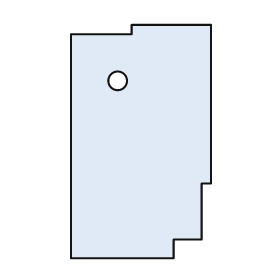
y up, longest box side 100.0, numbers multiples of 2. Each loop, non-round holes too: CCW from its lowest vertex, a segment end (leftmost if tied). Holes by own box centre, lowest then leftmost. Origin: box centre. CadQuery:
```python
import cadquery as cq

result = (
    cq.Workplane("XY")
    .moveTo(-30.0, -50.0)
    .lineTo(14.0, -50.0)
    .lineTo(14.0, -42.0)
    .lineTo(26.0, -42.0)
    .lineTo(26.0, -18.0)
    .lineTo(30.0, -18.0)
    .lineTo(30.0, 50.0)
    .lineTo(-4.0, 50.0)
    .lineTo(-4.0, 46.0)
    .lineTo(-30.0, 46.0)
    .close()
    .moveTo(-10.0, 26.0)
    .circle(4.0)
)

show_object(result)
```